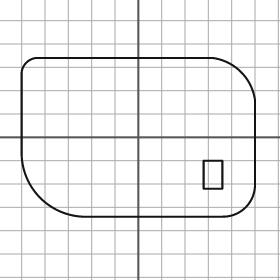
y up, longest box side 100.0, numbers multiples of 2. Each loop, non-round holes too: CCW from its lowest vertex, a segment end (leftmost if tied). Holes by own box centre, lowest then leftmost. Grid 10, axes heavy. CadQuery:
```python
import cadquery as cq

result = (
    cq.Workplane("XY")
    .moveTo(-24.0, -34.0)
    .lineTo(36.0, -34.0)
    .threePointArc((46.0, -30.0), (50.0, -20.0))
    .lineTo(50.0, 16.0)
    .threePointArc((44.0, 28.0), (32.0, 34.0))
    .lineTo(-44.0, 34.0)
    .threePointArc((-48.0, 32.0), (-50.0, 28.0))
    .lineTo(-50.0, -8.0)
    .threePointArc((-42.0, -26.0), (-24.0, -34.0))
    .close()
    .moveTo(28.0, -22.0)
    .lineTo(36.0, -22.0)
    .lineTo(36.0, -10.0)
    .lineTo(28.0, -10.0)
    .close()
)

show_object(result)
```